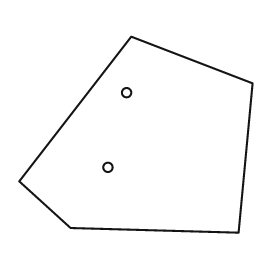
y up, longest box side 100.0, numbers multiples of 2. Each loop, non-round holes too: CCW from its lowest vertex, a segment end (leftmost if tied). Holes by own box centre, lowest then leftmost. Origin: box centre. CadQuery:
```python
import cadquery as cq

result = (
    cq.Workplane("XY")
    .moveTo(44.0, -42.0)
    .lineTo(50.0, 22.0)
    .lineTo(-2.0, 42.0)
    .lineTo(-50.0, -20.0)
    .lineTo(-28.0, -40.0)
    .close()
    .moveTo(-12.0, -14.0)
    .circle(2.0)
    .moveTo(-4.0, 18.0)
    .circle(2.0)
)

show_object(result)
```